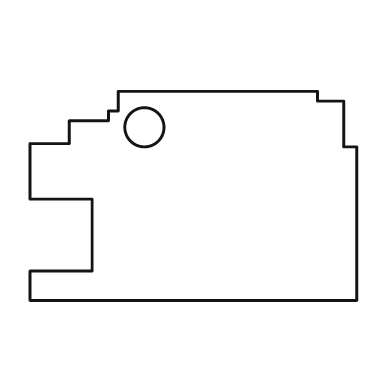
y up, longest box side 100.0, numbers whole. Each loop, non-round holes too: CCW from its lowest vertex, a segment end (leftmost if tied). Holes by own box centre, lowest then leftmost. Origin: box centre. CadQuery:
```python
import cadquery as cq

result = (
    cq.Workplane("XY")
    .moveTo(-50.0, -32.0)
    .lineTo(50.0, -32.0)
    .lineTo(50.0, 15.0)
    .lineTo(46.0, 15.0)
    .lineTo(46.0, 29.0)
    .lineTo(38.0, 29.0)
    .lineTo(38.0, 32.0)
    .lineTo(-23.0, 32.0)
    .lineTo(-23.0, 26.0)
    .lineTo(-26.0, 26.0)
    .lineTo(-26.0, 23.0)
    .lineTo(-38.0, 23.0)
    .lineTo(-38.0, 16.0)
    .lineTo(-50.0, 16.0)
    .lineTo(-50.0, -1.0)
    .lineTo(-31.0, -1.0)
    .lineTo(-31.0, -23.0)
    .lineTo(-50.0, -23.0)
    .close()
    .moveTo(-15.0, 21.0)
    .circle(6.0)
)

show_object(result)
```